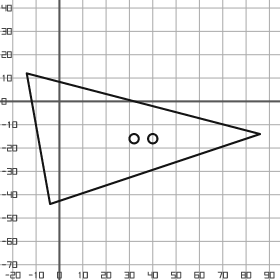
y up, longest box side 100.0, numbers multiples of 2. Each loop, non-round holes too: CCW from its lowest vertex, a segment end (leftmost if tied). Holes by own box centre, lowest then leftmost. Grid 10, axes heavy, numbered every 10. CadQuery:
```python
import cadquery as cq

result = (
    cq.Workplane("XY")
    .moveTo(-4.0, -44.0)
    .lineTo(86.0, -14.0)
    .lineTo(-14.0, 12.0)
    .close()
    .moveTo(32.0, -16.0)
    .circle(2.0)
    .moveTo(40.0, -16.0)
    .circle(2.0)
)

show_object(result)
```